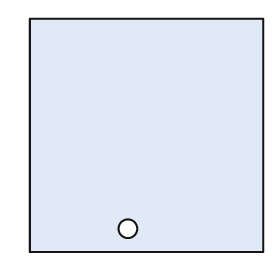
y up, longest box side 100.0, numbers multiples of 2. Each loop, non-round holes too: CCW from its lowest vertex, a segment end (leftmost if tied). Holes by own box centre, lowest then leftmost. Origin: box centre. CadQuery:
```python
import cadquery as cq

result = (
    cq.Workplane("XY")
    .moveTo(-50.0, -50.0)
    .lineTo(50.0, -50.0)
    .lineTo(50.0, 50.0)
    .lineTo(-50.0, 50.0)
    .close()
    .moveTo(-8.0, -40.0)
    .circle(4.0)
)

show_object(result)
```